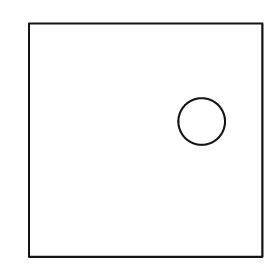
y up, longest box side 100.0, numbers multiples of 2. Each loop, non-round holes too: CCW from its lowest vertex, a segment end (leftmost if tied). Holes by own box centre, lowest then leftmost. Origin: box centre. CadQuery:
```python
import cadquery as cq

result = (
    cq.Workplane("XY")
    .moveTo(-50.0, -50.0)
    .lineTo(50.0, -50.0)
    .lineTo(50.0, 50.0)
    .lineTo(-50.0, 50.0)
    .close()
    .moveTo(24.0, 8.0)
    .circle(10.0)
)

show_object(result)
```